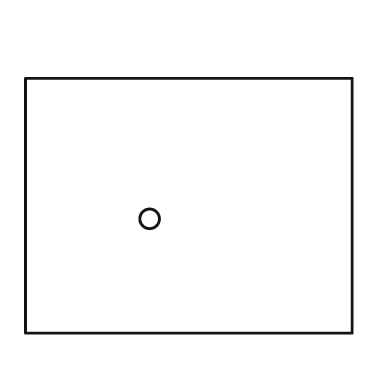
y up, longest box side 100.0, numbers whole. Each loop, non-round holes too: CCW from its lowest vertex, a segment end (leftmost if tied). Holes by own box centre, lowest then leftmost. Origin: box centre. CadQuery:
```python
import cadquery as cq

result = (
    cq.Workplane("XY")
    .moveTo(-50.0, -39.0)
    .lineTo(50.0, -39.0)
    .lineTo(50.0, 39.0)
    .lineTo(-50.0, 39.0)
    .close()
    .moveTo(-12.0, -4.0)
    .circle(3.0)
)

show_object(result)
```